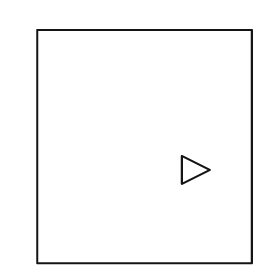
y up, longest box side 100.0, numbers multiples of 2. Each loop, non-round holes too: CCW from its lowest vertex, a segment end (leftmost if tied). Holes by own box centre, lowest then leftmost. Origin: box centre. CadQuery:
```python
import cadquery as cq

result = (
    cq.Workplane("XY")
    .moveTo(-46.0, -50.0)
    .lineTo(46.0, -50.0)
    .lineTo(46.0, 50.0)
    .lineTo(-46.0, 50.0)
    .close()
    .moveTo(16.0, -16.0)
    .lineTo(28.0, -10.0)
    .lineTo(16.0, -4.0)
    .close()
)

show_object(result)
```